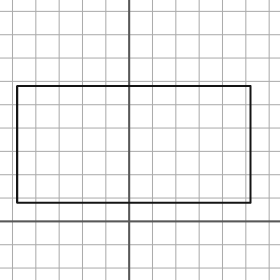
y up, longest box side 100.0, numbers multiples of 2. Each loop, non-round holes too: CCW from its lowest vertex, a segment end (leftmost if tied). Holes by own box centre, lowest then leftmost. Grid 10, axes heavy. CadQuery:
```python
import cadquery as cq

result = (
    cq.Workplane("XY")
    .moveTo(-48.0, 8.0)
    .lineTo(52.0, 8.0)
    .lineTo(52.0, 58.0)
    .lineTo(-48.0, 58.0)
    .close()
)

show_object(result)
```